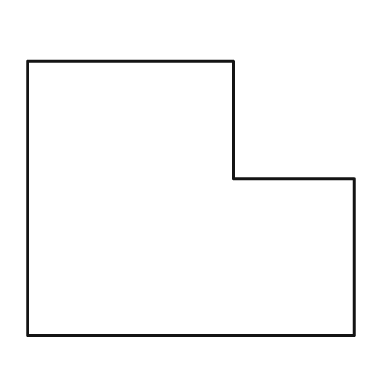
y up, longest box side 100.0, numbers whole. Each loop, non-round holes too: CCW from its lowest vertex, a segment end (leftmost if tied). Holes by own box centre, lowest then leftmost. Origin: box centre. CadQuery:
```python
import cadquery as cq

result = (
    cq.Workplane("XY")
    .moveTo(-50.0, -42.0)
    .lineTo(50.0, -42.0)
    .lineTo(50.0, 6.0)
    .lineTo(13.0, 6.0)
    .lineTo(13.0, 42.0)
    .lineTo(-50.0, 42.0)
    .close()
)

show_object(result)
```